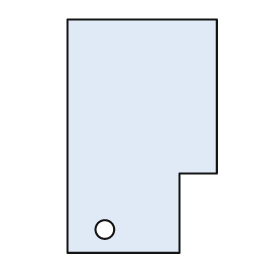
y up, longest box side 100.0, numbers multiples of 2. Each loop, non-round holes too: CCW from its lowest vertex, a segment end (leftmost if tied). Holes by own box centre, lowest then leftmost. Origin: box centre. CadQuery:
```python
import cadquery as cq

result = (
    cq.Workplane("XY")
    .moveTo(-32.0, -50.0)
    .lineTo(16.0, -50.0)
    .lineTo(16.0, -16.0)
    .lineTo(32.0, -16.0)
    .lineTo(32.0, 50.0)
    .lineTo(-32.0, 50.0)
    .close()
    .moveTo(-16.0, -40.0)
    .circle(4.0)
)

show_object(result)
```